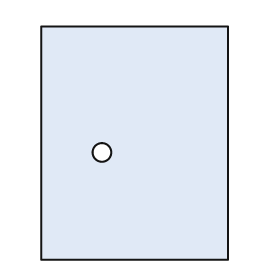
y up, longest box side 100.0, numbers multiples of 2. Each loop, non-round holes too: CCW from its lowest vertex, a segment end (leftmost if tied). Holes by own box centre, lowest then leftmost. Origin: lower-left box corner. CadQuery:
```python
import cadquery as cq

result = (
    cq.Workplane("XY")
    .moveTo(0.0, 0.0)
    .lineTo(80.0, 0.0)
    .lineTo(80.0, 100.0)
    .lineTo(0.0, 100.0)
    .close()
    .moveTo(26.0, 46.0)
    .circle(4.0)
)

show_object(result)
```